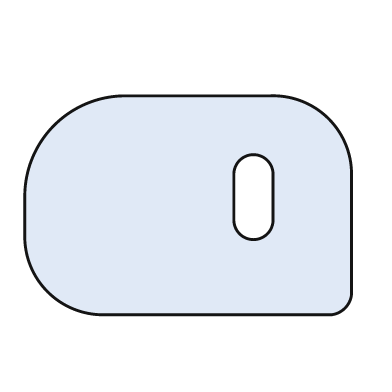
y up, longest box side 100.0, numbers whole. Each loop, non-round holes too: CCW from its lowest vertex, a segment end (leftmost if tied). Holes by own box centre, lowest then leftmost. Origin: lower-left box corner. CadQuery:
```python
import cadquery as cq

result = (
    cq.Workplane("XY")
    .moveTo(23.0, 0.0)
    .lineTo(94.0, 0.0)
    .threePointArc((98.0, 2.0), (100.0, 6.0))
    .lineTo(100.0, 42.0)
    .threePointArc((93.0, 60.0), (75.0, 67.0))
    .lineTo(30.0, 67.0)
    .threePointArc((9.0, 58.0), (0.0, 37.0))
    .lineTo(0.0, 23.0)
    .threePointArc((7.0, 7.0), (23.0, 0.0))
    .close()
    .moveTo(64.0, 29.0)
    .threePointArc((70.0, 23.0), (76.0, 29.0))
    .lineTo(76.0, 43.0)
    .threePointArc((70.0, 49.0), (64.0, 43.0))
    .close()
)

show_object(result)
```